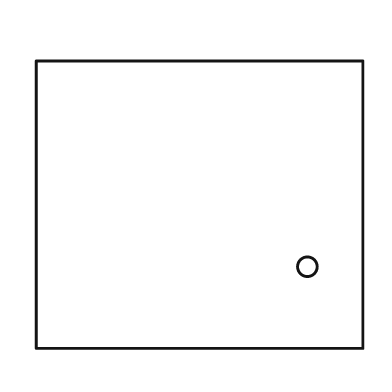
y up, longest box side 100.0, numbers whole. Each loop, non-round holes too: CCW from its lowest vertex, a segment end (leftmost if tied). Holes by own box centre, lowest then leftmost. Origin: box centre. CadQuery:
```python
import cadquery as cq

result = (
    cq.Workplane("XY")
    .moveTo(-50.0, -44.0)
    .lineTo(50.0, -44.0)
    .lineTo(50.0, 44.0)
    .lineTo(-50.0, 44.0)
    .close()
    .moveTo(33.0, -19.0)
    .circle(3.0)
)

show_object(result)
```